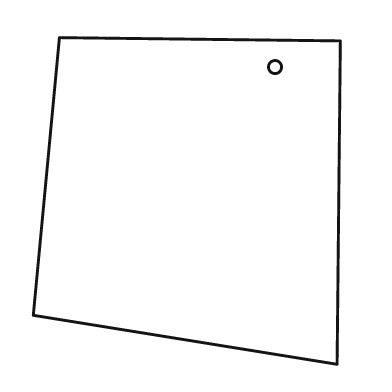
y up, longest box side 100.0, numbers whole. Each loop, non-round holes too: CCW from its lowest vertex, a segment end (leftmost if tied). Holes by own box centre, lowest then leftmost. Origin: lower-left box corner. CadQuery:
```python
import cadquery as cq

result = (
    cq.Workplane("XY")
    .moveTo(93.0, 0.0)
    .lineTo(94.0, 99.0)
    .lineTo(8.0, 100.0)
    .lineTo(0.0, 15.0)
    .close()
    .moveTo(74.0, 91.0)
    .circle(2.0)
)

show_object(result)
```